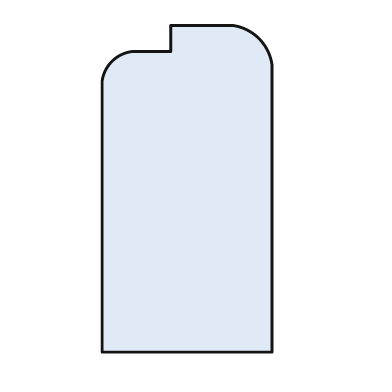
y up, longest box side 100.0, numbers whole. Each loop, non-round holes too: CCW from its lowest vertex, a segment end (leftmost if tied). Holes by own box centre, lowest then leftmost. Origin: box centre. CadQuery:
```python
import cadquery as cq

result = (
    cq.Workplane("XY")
    .moveTo(-26.0, -50.0)
    .lineTo(26.0, -50.0)
    .lineTo(26.0, 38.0)
    .threePointArc((22.0, 46.0), (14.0, 50.0))
    .lineTo(-5.0, 50.0)
    .lineTo(-5.0, 42.0)
    .lineTo(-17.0, 42.0)
    .threePointArc((-23.0, 39.0), (-26.0, 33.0))
    .close()
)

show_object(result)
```